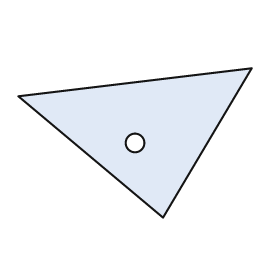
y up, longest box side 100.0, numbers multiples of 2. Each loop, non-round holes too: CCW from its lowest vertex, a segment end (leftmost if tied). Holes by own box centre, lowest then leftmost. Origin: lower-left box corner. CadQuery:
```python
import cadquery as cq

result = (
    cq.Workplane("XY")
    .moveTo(62.0, 0.0)
    .lineTo(100.0, 64.0)
    .lineTo(0.0, 52.0)
    .close()
    .moveTo(50.0, 32.0)
    .circle(4.0)
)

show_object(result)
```